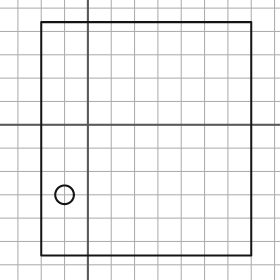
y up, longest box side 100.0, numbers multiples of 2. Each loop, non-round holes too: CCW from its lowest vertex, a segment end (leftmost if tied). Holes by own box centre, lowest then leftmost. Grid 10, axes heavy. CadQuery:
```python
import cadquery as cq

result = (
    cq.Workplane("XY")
    .moveTo(-20.0, -56.0)
    .lineTo(70.0, -56.0)
    .lineTo(70.0, 44.0)
    .lineTo(-20.0, 44.0)
    .close()
    .moveTo(-10.0, -30.0)
    .circle(4.0)
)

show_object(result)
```